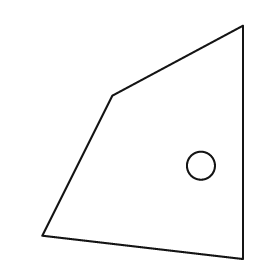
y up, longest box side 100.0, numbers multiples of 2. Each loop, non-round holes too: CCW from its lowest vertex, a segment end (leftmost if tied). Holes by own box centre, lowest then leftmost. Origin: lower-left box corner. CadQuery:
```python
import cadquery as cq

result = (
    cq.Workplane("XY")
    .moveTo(86.0, 0.0)
    .lineTo(86.0, 100.0)
    .lineTo(30.0, 70.0)
    .lineTo(0.0, 10.0)
    .close()
    .moveTo(68.0, 40.0)
    .circle(6.0)
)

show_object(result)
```